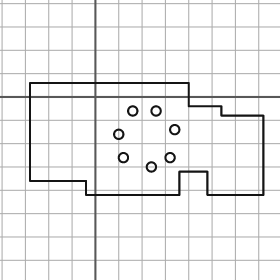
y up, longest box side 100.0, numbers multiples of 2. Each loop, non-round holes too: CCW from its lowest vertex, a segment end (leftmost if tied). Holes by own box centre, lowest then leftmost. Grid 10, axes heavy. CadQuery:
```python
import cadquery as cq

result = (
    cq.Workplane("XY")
    .moveTo(-4.0, -42.0)
    .lineTo(36.0, -42.0)
    .lineTo(36.0, -32.0)
    .lineTo(48.0, -32.0)
    .lineTo(48.0, -42.0)
    .lineTo(72.0, -42.0)
    .lineTo(72.0, -8.0)
    .lineTo(54.0, -8.0)
    .lineTo(54.0, -4.0)
    .lineTo(40.0, -4.0)
    .lineTo(40.0, 6.0)
    .lineTo(-28.0, 6.0)
    .lineTo(-28.0, -36.0)
    .lineTo(-4.0, -36.0)
    .close()
    .moveTo(24.0, -30.0)
    .circle(2.0)
    .moveTo(12.0, -26.0)
    .circle(2.0)
    .moveTo(32.0, -26.0)
    .circle(2.0)
    .moveTo(10.0, -16.0)
    .circle(2.0)
    .moveTo(34.0, -14.0)
    .circle(2.0)
    .moveTo(16.0, -6.0)
    .circle(2.0)
    .moveTo(26.0, -6.0)
    .circle(2.0)
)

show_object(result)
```